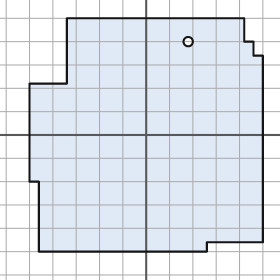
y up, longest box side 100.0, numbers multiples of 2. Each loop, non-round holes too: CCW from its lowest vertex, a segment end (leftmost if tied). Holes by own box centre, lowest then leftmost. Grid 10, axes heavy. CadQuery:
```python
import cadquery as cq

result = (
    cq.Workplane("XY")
    .moveTo(-46.0, -50.0)
    .lineTo(26.0, -50.0)
    .lineTo(26.0, -46.0)
    .lineTo(50.0, -46.0)
    .lineTo(50.0, 34.0)
    .lineTo(46.0, 34.0)
    .lineTo(46.0, 40.0)
    .lineTo(42.0, 40.0)
    .lineTo(42.0, 50.0)
    .lineTo(-34.0, 50.0)
    .lineTo(-34.0, 22.0)
    .lineTo(-50.0, 22.0)
    .lineTo(-50.0, -20.0)
    .lineTo(-46.0, -20.0)
    .close()
    .moveTo(18.0, 40.0)
    .circle(2.0)
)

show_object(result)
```